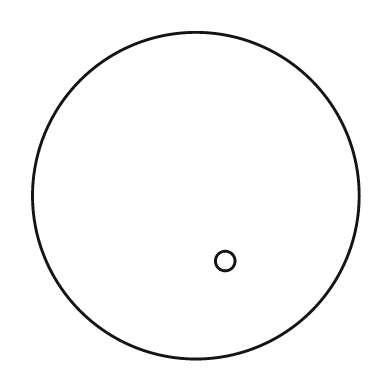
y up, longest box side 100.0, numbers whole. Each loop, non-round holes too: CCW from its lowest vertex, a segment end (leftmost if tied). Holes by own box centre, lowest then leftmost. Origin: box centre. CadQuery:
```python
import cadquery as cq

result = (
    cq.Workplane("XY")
    .moveTo(0.0, 0.0)
    .circle(50.0)
    .moveTo(9.0, -20.0)
    .circle(3.0)
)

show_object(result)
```